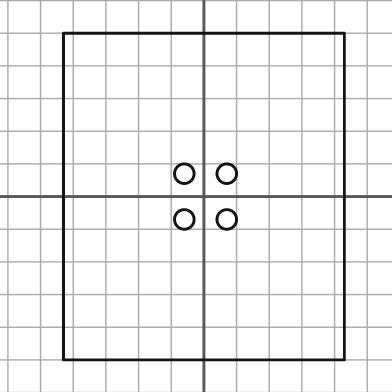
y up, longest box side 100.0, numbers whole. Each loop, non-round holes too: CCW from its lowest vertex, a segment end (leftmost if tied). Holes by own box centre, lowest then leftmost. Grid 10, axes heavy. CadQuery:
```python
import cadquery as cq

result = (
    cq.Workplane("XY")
    .moveTo(-43.0, -50.0)
    .lineTo(43.0, -50.0)
    .lineTo(43.0, 50.0)
    .lineTo(-43.0, 50.0)
    .close()
    .moveTo(-6.0, -7.0)
    .circle(3.0)
    .moveTo(7.0, -7.0)
    .circle(3.0)
    .moveTo(-6.0, 7.0)
    .circle(3.0)
    .moveTo(7.0, 7.0)
    .circle(3.0)
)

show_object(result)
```